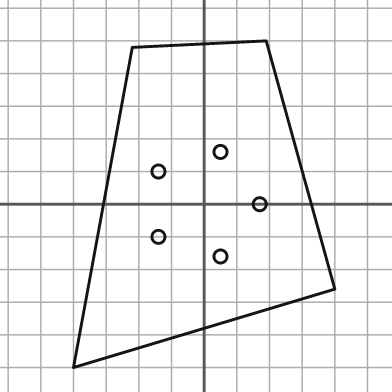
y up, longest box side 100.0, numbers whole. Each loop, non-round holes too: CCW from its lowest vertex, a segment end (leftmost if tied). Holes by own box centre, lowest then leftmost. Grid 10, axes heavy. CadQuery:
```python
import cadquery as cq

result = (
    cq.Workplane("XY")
    .moveTo(-40.0, -50.0)
    .lineTo(40.0, -26.0)
    .lineTo(19.0, 50.0)
    .lineTo(-22.0, 48.0)
    .close()
    .moveTo(5.0, -16.0)
    .circle(2.0)
    .moveTo(-14.0, -10.0)
    .circle(2.0)
    .moveTo(17.0, 0.0)
    .circle(2.0)
    .moveTo(-14.0, 10.0)
    .circle(2.0)
    .moveTo(5.0, 16.0)
    .circle(2.0)
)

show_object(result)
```